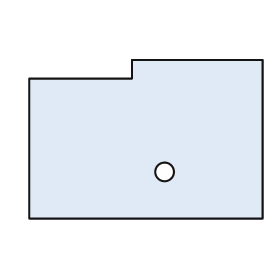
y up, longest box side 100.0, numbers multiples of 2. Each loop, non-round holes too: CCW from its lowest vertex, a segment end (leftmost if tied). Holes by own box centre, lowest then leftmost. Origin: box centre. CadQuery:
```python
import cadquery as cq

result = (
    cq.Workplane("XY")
    .moveTo(-50.0, -34.0)
    .lineTo(50.0, -34.0)
    .lineTo(50.0, 34.0)
    .lineTo(-6.0, 34.0)
    .lineTo(-6.0, 26.0)
    .lineTo(-50.0, 26.0)
    .close()
    .moveTo(8.0, -14.0)
    .circle(4.0)
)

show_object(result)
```